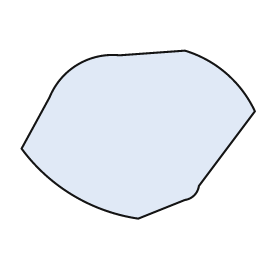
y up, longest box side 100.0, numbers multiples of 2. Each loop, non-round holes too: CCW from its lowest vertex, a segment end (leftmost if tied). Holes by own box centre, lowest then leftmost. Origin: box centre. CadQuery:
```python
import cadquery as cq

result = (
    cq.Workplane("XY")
    .moveTo(0.0, -36.0)
    .lineTo(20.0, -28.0)
    .threePointArc((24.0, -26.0), (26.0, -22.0))
    .lineTo(50.0, 10.0)
    .threePointArc((38.0, 26.0), (20.0, 36.0))
    .lineTo(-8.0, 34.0)
    .threePointArc((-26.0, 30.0), (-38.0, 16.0))
    .lineTo(-50.0, -6.0)
    .threePointArc((-28.0, -26.0), (0.0, -36.0))
    .close()
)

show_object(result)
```